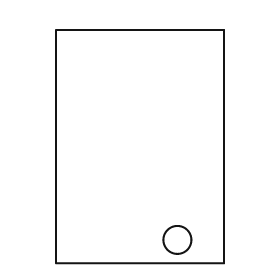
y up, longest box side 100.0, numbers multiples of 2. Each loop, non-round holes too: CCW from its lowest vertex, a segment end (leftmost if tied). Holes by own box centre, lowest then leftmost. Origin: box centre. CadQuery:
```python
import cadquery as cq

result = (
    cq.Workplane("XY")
    .moveTo(-36.0, -50.0)
    .lineTo(36.0, -50.0)
    .lineTo(36.0, 50.0)
    .lineTo(-36.0, 50.0)
    .close()
    .moveTo(16.0, -40.0)
    .circle(6.0)
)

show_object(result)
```